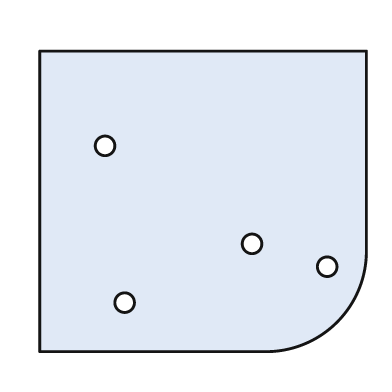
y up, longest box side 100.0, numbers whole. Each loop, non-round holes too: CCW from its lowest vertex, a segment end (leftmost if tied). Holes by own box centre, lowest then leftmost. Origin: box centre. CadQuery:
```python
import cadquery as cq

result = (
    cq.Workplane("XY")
    .moveTo(-50.0, -46.0)
    .lineTo(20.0, -46.0)
    .threePointArc((41.0, -37.0), (50.0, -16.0))
    .lineTo(50.0, 46.0)
    .lineTo(-50.0, 46.0)
    .close()
    .moveTo(-24.0, -31.0)
    .circle(3.0)
    .moveTo(38.0, -20.0)
    .circle(3.0)
    .moveTo(15.0, -13.0)
    .circle(3.0)
    .moveTo(-30.0, 17.0)
    .circle(3.0)
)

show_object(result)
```